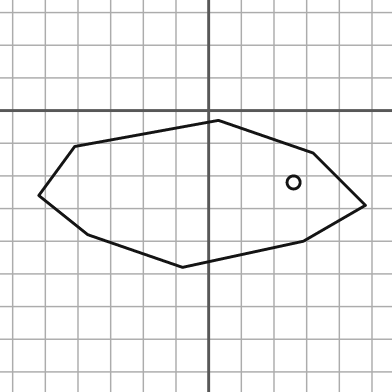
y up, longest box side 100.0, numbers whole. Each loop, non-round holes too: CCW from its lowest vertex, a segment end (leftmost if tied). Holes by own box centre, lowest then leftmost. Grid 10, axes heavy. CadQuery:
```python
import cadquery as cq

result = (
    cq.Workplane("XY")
    .moveTo(-8.0, -48.0)
    .lineTo(29.0, -40.0)
    .lineTo(48.0, -29.0)
    .lineTo(32.0, -13.0)
    .lineTo(3.0, -3.0)
    .lineTo(-41.0, -11.0)
    .lineTo(-52.0, -26.0)
    .lineTo(-37.0, -38.0)
    .close()
    .moveTo(26.0, -22.0)
    .circle(2.0)
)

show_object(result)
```